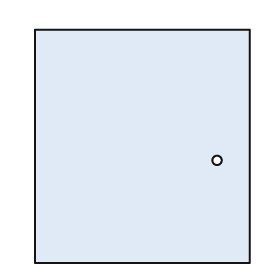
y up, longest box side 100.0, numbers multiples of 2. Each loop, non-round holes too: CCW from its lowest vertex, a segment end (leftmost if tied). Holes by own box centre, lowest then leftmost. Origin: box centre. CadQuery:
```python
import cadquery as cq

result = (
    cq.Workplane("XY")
    .moveTo(-46.0, -50.0)
    .lineTo(46.0, -50.0)
    .lineTo(46.0, 50.0)
    .lineTo(-46.0, 50.0)
    .close()
    .moveTo(32.0, -6.0)
    .circle(2.0)
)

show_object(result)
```